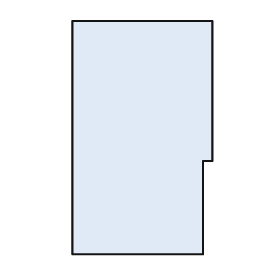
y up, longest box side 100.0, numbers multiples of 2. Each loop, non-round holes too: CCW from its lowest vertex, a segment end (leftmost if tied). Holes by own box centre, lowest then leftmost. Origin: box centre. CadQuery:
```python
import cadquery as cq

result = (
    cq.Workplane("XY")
    .moveTo(-30.0, -50.0)
    .lineTo(26.0, -50.0)
    .lineTo(26.0, -10.0)
    .lineTo(30.0, -10.0)
    .lineTo(30.0, 50.0)
    .lineTo(-30.0, 50.0)
    .close()
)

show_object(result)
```